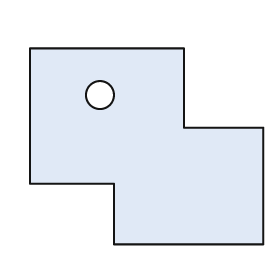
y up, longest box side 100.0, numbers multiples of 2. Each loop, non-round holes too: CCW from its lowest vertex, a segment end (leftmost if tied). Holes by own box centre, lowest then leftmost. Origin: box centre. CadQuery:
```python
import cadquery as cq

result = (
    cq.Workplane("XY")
    .moveTo(-14.0, -42.0)
    .lineTo(50.0, -42.0)
    .lineTo(50.0, 8.0)
    .lineTo(16.0, 8.0)
    .lineTo(16.0, 42.0)
    .lineTo(-50.0, 42.0)
    .lineTo(-50.0, -16.0)
    .lineTo(-14.0, -16.0)
    .close()
    .moveTo(-20.0, 22.0)
    .circle(6.0)
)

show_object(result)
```